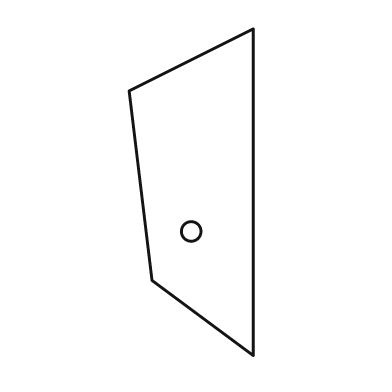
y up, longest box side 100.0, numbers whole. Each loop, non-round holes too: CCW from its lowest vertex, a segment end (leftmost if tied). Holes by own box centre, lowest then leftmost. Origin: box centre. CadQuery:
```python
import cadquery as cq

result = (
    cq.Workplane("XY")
    .moveTo(19.0, -50.0)
    .lineTo(19.0, 50.0)
    .lineTo(-19.0, 31.0)
    .lineTo(-12.0, -27.0)
    .close()
    .moveTo(0.0, -12.0)
    .circle(3.0)
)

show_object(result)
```